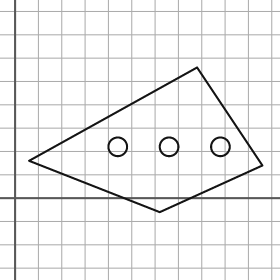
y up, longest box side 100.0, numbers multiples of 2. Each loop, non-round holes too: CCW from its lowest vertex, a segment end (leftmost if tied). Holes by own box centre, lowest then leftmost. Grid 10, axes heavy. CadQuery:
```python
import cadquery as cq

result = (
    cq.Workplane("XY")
    .moveTo(62.0, -6.0)
    .lineTo(106.0, 14.0)
    .lineTo(78.0, 56.0)
    .lineTo(6.0, 16.0)
    .close()
    .moveTo(44.0, 22.0)
    .circle(4.0)
    .moveTo(66.0, 22.0)
    .circle(4.0)
    .moveTo(88.0, 22.0)
    .circle(4.0)
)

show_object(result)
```